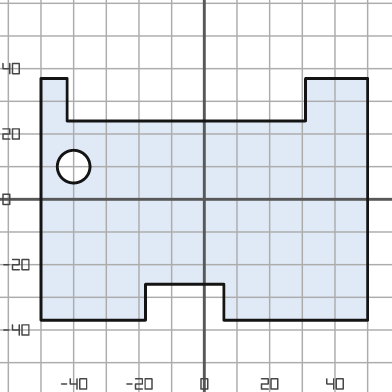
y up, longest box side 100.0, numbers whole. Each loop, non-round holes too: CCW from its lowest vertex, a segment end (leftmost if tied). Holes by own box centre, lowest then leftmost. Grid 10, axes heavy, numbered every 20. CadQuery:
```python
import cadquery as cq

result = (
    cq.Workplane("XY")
    .moveTo(-50.0, -37.0)
    .lineTo(-18.0, -37.0)
    .lineTo(-18.0, -26.0)
    .lineTo(6.0, -26.0)
    .lineTo(6.0, -37.0)
    .lineTo(50.0, -37.0)
    .lineTo(50.0, 37.0)
    .lineTo(31.0, 37.0)
    .lineTo(31.0, 24.0)
    .lineTo(-42.0, 24.0)
    .lineTo(-42.0, 37.0)
    .lineTo(-50.0, 37.0)
    .close()
    .moveTo(-40.0, 10.0)
    .circle(5.0)
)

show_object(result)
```